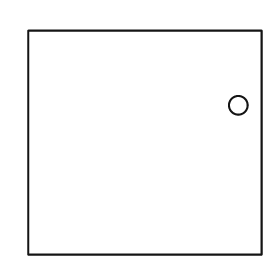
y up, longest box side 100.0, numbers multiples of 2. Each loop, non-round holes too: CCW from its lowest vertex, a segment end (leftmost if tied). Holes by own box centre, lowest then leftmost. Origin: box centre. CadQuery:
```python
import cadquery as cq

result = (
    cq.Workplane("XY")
    .moveTo(-50.0, -48.0)
    .lineTo(50.0, -48.0)
    .lineTo(50.0, 48.0)
    .lineTo(-50.0, 48.0)
    .close()
    .moveTo(40.0, 16.0)
    .circle(4.0)
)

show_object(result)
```